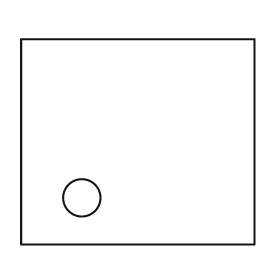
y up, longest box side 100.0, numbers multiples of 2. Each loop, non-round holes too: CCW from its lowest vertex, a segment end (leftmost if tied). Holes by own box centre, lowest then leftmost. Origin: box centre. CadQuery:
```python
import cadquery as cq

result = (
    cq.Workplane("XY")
    .moveTo(-50.0, -44.0)
    .lineTo(50.0, -44.0)
    .lineTo(50.0, 44.0)
    .lineTo(-50.0, 44.0)
    .close()
    .moveTo(-24.0, -24.0)
    .circle(8.0)
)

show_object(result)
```